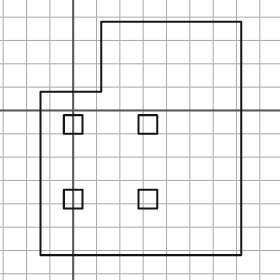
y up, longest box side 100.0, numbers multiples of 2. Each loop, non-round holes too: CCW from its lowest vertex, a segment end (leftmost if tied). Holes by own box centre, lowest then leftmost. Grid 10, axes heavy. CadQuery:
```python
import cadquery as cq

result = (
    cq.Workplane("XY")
    .moveTo(-14.0, -62.0)
    .lineTo(72.0, -62.0)
    .lineTo(72.0, 38.0)
    .lineTo(12.0, 38.0)
    .lineTo(12.0, 8.0)
    .lineTo(-14.0, 8.0)
    .close()
    .moveTo(-4.0, -42.0)
    .lineTo(4.0, -42.0)
    .lineTo(4.0, -34.0)
    .lineTo(-4.0, -34.0)
    .close()
    .moveTo(28.0, -42.0)
    .lineTo(36.0, -42.0)
    .lineTo(36.0, -34.0)
    .lineTo(28.0, -34.0)
    .close()
    .moveTo(-4.0, -10.0)
    .lineTo(4.0, -10.0)
    .lineTo(4.0, -2.0)
    .lineTo(-4.0, -2.0)
    .close()
    .moveTo(28.0, -10.0)
    .lineTo(36.0, -10.0)
    .lineTo(36.0, -2.0)
    .lineTo(28.0, -2.0)
    .close()
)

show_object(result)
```